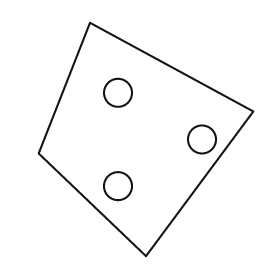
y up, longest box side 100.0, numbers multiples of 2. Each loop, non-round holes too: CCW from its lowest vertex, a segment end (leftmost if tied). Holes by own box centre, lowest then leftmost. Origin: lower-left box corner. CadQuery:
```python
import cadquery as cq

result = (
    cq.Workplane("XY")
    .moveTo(46.0, 0.0)
    .lineTo(92.0, 62.0)
    .lineTo(22.0, 100.0)
    .lineTo(0.0, 44.0)
    .close()
    .moveTo(34.0, 30.0)
    .circle(6.0)
    .moveTo(70.0, 50.0)
    .circle(6.0)
    .moveTo(34.0, 70.0)
    .circle(6.0)
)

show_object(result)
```